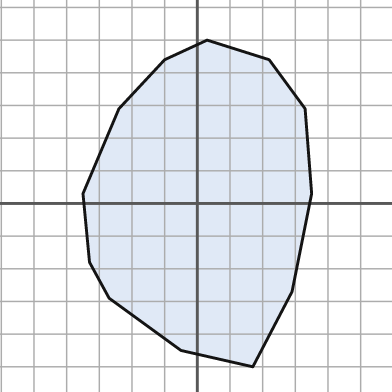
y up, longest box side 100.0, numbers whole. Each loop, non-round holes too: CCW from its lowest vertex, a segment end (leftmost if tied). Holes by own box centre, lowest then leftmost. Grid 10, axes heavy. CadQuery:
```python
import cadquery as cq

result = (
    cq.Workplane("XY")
    .moveTo(17.0, -50.0)
    .lineTo(29.0, -27.0)
    .lineTo(35.0, 3.0)
    .lineTo(33.0, 29.0)
    .lineTo(22.0, 44.0)
    .lineTo(3.0, 50.0)
    .lineTo(-10.0, 44.0)
    .lineTo(-24.0, 29.0)
    .lineTo(-35.0, 3.0)
    .lineTo(-33.0, -18.0)
    .lineTo(-27.0, -29.0)
    .lineTo(-5.0, -45.0)
    .close()
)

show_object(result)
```